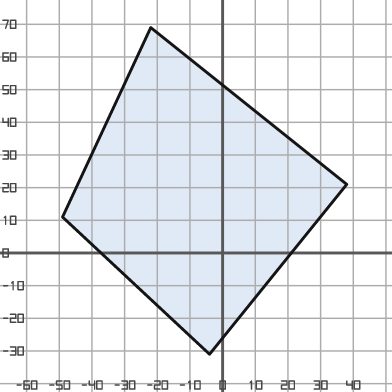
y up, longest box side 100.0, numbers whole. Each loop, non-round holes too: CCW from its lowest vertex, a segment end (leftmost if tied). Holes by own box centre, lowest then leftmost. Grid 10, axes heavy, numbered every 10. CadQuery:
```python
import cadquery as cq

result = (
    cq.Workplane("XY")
    .moveTo(-4.0, -31.0)
    .lineTo(38.0, 21.0)
    .lineTo(-22.0, 69.0)
    .lineTo(-49.0, 11.0)
    .close()
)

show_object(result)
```